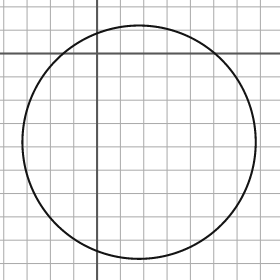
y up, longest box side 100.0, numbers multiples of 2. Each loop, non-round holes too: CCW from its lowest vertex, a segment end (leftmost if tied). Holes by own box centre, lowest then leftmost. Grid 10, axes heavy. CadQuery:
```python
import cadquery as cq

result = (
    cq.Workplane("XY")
    .moveTo(18.0, -38.0)
    .circle(50.0)
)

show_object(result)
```